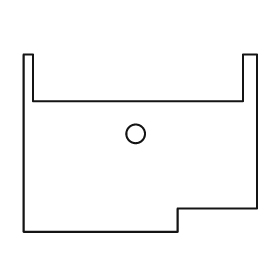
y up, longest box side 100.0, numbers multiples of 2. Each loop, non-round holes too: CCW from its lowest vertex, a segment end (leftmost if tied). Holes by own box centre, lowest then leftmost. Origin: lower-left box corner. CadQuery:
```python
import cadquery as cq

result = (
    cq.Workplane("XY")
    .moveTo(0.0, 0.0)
    .lineTo(66.0, 0.0)
    .lineTo(66.0, 10.0)
    .lineTo(100.0, 10.0)
    .lineTo(100.0, 76.0)
    .lineTo(94.0, 76.0)
    .lineTo(94.0, 56.0)
    .lineTo(4.0, 56.0)
    .lineTo(4.0, 76.0)
    .lineTo(0.0, 76.0)
    .close()
    .moveTo(48.0, 42.0)
    .circle(4.0)
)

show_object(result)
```